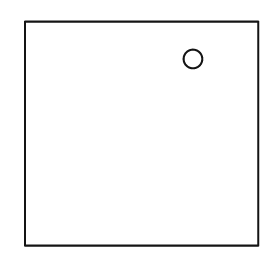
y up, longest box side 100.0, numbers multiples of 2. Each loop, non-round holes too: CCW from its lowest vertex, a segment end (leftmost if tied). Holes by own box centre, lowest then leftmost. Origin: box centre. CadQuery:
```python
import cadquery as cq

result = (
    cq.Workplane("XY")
    .moveTo(-50.0, -48.0)
    .lineTo(50.0, -48.0)
    .lineTo(50.0, 48.0)
    .lineTo(-50.0, 48.0)
    .close()
    .moveTo(22.0, 32.0)
    .circle(4.0)
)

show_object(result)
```